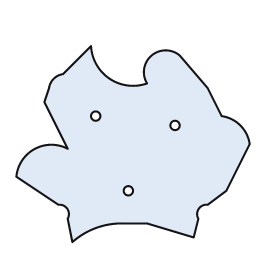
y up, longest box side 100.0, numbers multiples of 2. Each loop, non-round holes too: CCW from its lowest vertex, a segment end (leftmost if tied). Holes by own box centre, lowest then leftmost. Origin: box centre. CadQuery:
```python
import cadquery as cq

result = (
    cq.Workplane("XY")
    .moveTo(-26.0, -42.0)
    .threePointArc((-16.0, -36.0), (-4.0, -34.0))
    .lineTo(6.0, -34.0)
    .lineTo(26.0, -40.0)
    .lineTo(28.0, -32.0)
    .threePointArc((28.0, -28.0), (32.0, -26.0))
    .lineTo(40.0, -20.0)
    .lineTo(50.0, 0.0)
    .threePointArc((46.0, 8.0), (38.0, 12.0))
    .lineTo(32.0, 24.0)
    .lineTo(20.0, 38.0)
    .threePointArc((8.0, 38.0), (6.0, 26.0))
    .threePointArc((-10.0, 28.0), (-18.0, 42.0))
    .lineTo(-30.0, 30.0)
    .threePointArc((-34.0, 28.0), (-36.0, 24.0))
    .lineTo(-38.0, 18.0)
    .lineTo(-28.0, -2.0)
    .threePointArc((-42.0, -2.0), (-50.0, -14.0))
    .lineTo(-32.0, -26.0)
    .threePointArc((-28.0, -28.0), (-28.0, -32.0))
    .close()
    .moveTo(-2.0, -20.0)
    .circle(2.0)
    .moveTo(18.0, 8.0)
    .circle(2.0)
    .moveTo(-16.0, 12.0)
    .circle(2.0)
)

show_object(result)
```